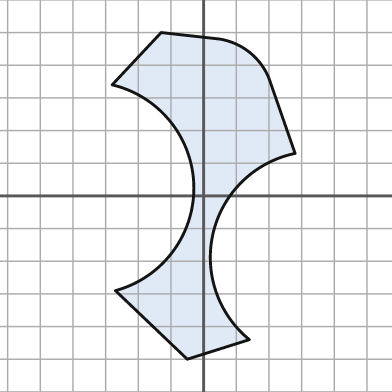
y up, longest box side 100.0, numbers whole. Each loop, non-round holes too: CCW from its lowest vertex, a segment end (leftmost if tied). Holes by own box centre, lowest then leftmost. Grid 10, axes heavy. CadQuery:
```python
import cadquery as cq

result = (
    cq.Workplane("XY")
    .moveTo(-5.0, -50.0)
    .lineTo(14.0, -44.0)
    .threePointArc((3.0, -11.0), (28.0, 13.0))
    .lineTo(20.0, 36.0)
    .threePointArc((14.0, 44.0), (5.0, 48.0))
    .lineTo(-13.0, 50.0)
    .lineTo(-28.0, 34.0)
    .threePointArc((-3.0, 3.0), (-27.0, -29.0))
    .close()
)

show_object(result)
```